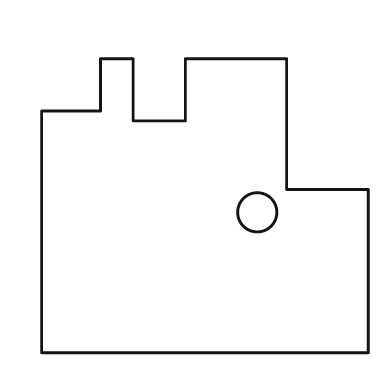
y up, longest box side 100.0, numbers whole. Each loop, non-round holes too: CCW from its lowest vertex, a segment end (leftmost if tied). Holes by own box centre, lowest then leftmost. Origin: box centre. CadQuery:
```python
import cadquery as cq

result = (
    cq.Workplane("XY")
    .moveTo(-50.0, -45.0)
    .lineTo(50.0, -45.0)
    .lineTo(50.0, 5.0)
    .lineTo(25.0, 5.0)
    .lineTo(25.0, 45.0)
    .lineTo(-6.0, 45.0)
    .lineTo(-6.0, 26.0)
    .lineTo(-22.0, 26.0)
    .lineTo(-22.0, 45.0)
    .lineTo(-32.0, 45.0)
    .lineTo(-32.0, 29.0)
    .lineTo(-50.0, 29.0)
    .close()
    .moveTo(16.0, -2.0)
    .circle(6.0)
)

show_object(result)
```